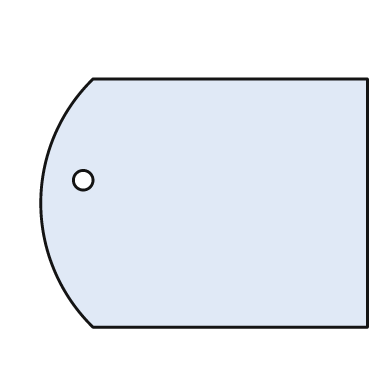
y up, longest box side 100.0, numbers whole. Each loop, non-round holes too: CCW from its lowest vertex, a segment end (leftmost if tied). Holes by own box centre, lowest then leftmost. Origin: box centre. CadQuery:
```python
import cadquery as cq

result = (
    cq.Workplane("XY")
    .moveTo(-34.0, -38.0)
    .lineTo(50.0, -38.0)
    .lineTo(50.0, 38.0)
    .lineTo(-34.0, 38.0)
    .threePointArc((-50.0, 0.0), (-34.0, -38.0))
    .close()
    .moveTo(-37.0, 7.0)
    .circle(3.0)
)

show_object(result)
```